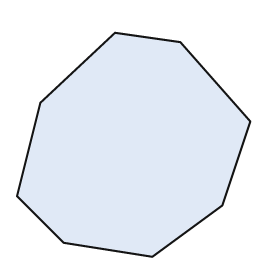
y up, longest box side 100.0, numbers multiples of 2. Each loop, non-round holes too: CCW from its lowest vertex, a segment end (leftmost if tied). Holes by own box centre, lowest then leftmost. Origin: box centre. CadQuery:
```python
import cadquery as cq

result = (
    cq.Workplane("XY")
    .moveTo(8.0, -48.0)
    .lineTo(38.0, -26.0)
    .lineTo(50.0, 10.0)
    .lineTo(20.0, 44.0)
    .lineTo(-8.0, 48.0)
    .lineTo(-40.0, 18.0)
    .lineTo(-50.0, -22.0)
    .lineTo(-30.0, -42.0)
    .close()
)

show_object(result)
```